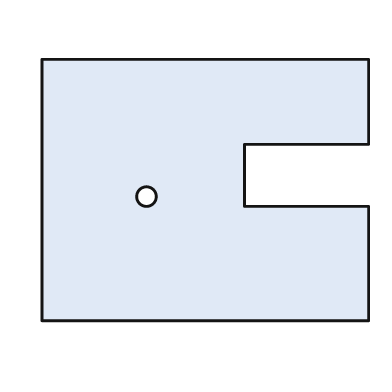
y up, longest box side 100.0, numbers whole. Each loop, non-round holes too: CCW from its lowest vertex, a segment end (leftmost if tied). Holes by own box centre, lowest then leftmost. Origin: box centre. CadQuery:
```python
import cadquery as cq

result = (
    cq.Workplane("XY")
    .moveTo(-50.0, -40.0)
    .lineTo(50.0, -40.0)
    .lineTo(50.0, -5.0)
    .lineTo(12.0, -5.0)
    .lineTo(12.0, 14.0)
    .lineTo(50.0, 14.0)
    .lineTo(50.0, 40.0)
    .lineTo(-50.0, 40.0)
    .close()
    .moveTo(-18.0, -2.0)
    .circle(3.0)
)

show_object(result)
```